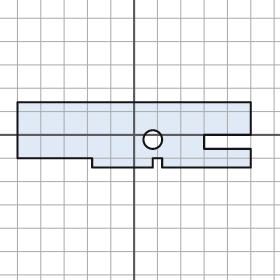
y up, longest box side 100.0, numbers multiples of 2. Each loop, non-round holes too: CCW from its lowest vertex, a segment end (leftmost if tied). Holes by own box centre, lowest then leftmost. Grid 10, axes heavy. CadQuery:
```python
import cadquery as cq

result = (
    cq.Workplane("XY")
    .moveTo(-18.0, -14.0)
    .lineTo(8.0, -14.0)
    .lineTo(8.0, -10.0)
    .lineTo(12.0, -10.0)
    .lineTo(12.0, -14.0)
    .lineTo(50.0, -14.0)
    .lineTo(50.0, -6.0)
    .lineTo(30.0, -6.0)
    .lineTo(30.0, 0.0)
    .lineTo(50.0, 0.0)
    .lineTo(50.0, 14.0)
    .lineTo(-50.0, 14.0)
    .lineTo(-50.0, -10.0)
    .lineTo(-18.0, -10.0)
    .close()
    .moveTo(8.0, -2.0)
    .circle(4.0)
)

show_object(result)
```